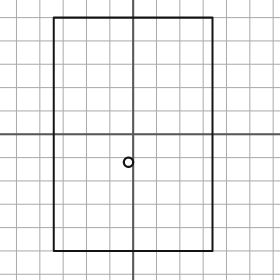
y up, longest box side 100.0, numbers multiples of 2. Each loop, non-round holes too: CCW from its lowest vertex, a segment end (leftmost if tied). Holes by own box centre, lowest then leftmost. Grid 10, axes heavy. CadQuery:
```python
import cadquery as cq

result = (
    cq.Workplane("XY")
    .moveTo(-34.0, -50.0)
    .lineTo(34.0, -50.0)
    .lineTo(34.0, 50.0)
    .lineTo(-34.0, 50.0)
    .close()
    .moveTo(-2.0, -12.0)
    .circle(2.0)
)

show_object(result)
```